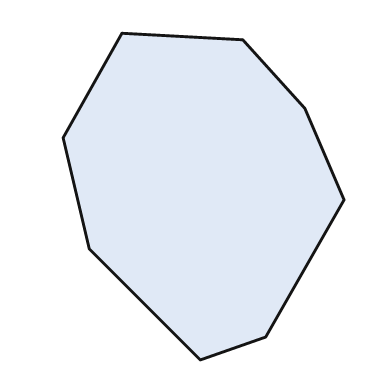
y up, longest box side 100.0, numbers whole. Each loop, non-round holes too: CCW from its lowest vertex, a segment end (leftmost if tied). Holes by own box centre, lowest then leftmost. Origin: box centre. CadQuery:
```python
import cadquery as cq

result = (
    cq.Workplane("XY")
    .moveTo(-1.0, -50.0)
    .lineTo(19.0, -43.0)
    .lineTo(43.0, -1.0)
    .lineTo(31.0, 27.0)
    .lineTo(12.0, 48.0)
    .lineTo(-25.0, 50.0)
    .lineTo(-43.0, 18.0)
    .lineTo(-35.0, -16.0)
    .close()
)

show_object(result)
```